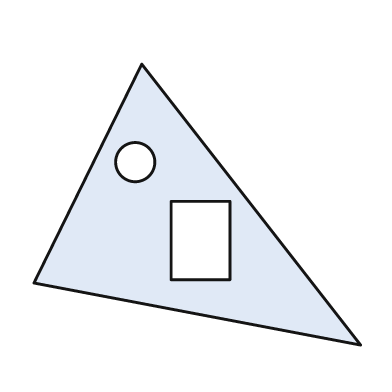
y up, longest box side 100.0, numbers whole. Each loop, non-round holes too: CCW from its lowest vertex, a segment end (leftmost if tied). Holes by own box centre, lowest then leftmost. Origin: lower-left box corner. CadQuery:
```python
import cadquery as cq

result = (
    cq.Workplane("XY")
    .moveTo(100.0, 0.0)
    .lineTo(33.0, 86.0)
    .lineTo(0.0, 19.0)
    .close()
    .moveTo(42.0, 20.0)
    .lineTo(60.0, 20.0)
    .lineTo(60.0, 44.0)
    .lineTo(42.0, 44.0)
    .close()
    .moveTo(31.0, 56.0)
    .circle(6.0)
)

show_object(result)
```